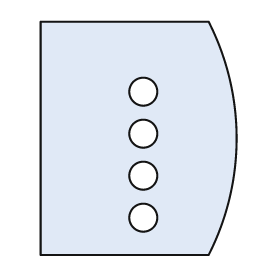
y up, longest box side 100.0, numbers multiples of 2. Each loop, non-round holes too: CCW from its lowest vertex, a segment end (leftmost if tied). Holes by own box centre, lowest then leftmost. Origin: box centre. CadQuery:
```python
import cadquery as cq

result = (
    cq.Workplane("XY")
    .moveTo(-42.0, -50.0)
    .lineTo(30.0, -50.0)
    .threePointArc((42.0, 0.0), (30.0, 50.0))
    .lineTo(-42.0, 50.0)
    .close()
    .moveTo(2.0, -34.0)
    .circle(6.0)
    .moveTo(2.0, -16.0)
    .circle(6.0)
    .moveTo(2.0, 2.0)
    .circle(6.0)
    .moveTo(2.0, 20.0)
    .circle(6.0)
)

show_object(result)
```